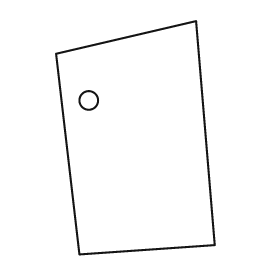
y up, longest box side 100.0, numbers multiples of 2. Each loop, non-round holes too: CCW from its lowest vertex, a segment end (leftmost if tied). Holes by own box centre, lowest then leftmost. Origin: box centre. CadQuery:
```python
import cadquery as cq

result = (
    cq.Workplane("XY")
    .moveTo(-24.0, -50.0)
    .lineTo(34.0, -46.0)
    .lineTo(26.0, 50.0)
    .lineTo(-34.0, 36.0)
    .close()
    .moveTo(-20.0, 16.0)
    .circle(4.0)
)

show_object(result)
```